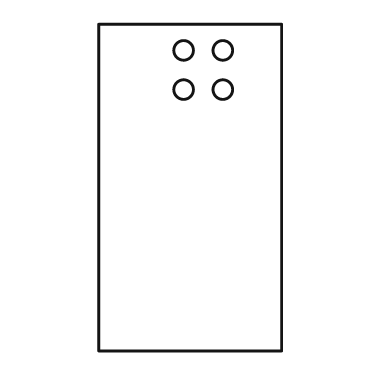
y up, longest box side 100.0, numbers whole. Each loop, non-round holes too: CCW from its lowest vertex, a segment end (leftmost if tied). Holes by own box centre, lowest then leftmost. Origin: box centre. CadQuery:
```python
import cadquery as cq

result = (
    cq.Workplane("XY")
    .moveTo(-28.0, -50.0)
    .lineTo(28.0, -50.0)
    .lineTo(28.0, 50.0)
    .lineTo(-28.0, 50.0)
    .close()
    .moveTo(-2.0, 30.0)
    .circle(3.0)
    .moveTo(10.0, 30.0)
    .circle(3.0)
    .moveTo(-2.0, 42.0)
    .circle(3.0)
    .moveTo(10.0, 42.0)
    .circle(3.0)
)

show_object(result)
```